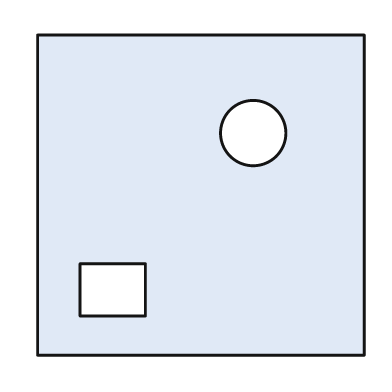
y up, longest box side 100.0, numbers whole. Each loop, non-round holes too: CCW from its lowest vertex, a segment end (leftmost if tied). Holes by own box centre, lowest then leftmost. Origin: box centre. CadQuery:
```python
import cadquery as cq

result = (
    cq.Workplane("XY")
    .moveTo(-50.0, -49.0)
    .lineTo(50.0, -49.0)
    .lineTo(50.0, 49.0)
    .lineTo(-50.0, 49.0)
    .close()
    .moveTo(-37.0, -37.0)
    .lineTo(-17.0, -37.0)
    .lineTo(-17.0, -21.0)
    .lineTo(-37.0, -21.0)
    .close()
    .moveTo(16.0, 19.0)
    .circle(10.0)
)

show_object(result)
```